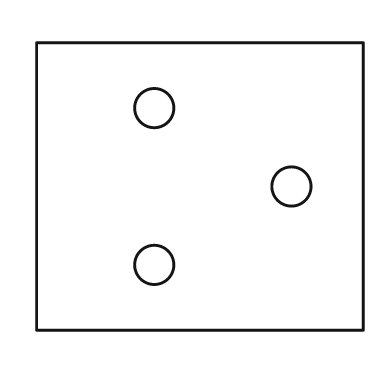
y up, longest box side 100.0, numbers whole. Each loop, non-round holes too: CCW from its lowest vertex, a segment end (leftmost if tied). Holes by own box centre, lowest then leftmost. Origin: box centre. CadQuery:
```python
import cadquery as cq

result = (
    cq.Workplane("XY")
    .moveTo(-50.0, -44.0)
    .lineTo(50.0, -44.0)
    .lineTo(50.0, 44.0)
    .lineTo(-50.0, 44.0)
    .close()
    .moveTo(-14.0, -24.0)
    .circle(6.0)
    .moveTo(28.0, 0.0)
    .circle(6.0)
    .moveTo(-14.0, 24.0)
    .circle(6.0)
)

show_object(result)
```